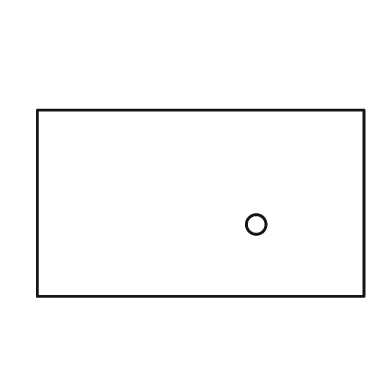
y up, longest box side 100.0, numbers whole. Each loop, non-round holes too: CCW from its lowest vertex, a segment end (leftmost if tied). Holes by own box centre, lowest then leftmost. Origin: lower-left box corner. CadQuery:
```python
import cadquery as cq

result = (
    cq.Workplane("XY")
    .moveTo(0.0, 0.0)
    .lineTo(100.0, 0.0)
    .lineTo(100.0, 57.0)
    .lineTo(0.0, 57.0)
    .close()
    .moveTo(67.0, 22.0)
    .circle(3.0)
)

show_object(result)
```